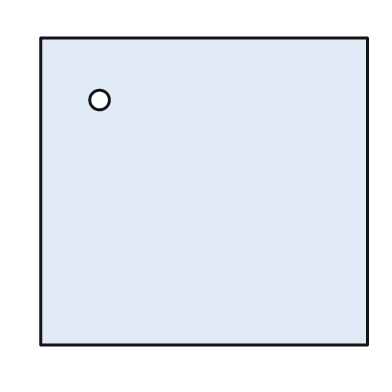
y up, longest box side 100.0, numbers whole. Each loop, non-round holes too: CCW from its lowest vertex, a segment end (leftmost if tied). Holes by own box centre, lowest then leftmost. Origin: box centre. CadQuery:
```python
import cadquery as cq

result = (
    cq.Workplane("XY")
    .moveTo(-50.0, -47.0)
    .lineTo(50.0, -47.0)
    .lineTo(50.0, 47.0)
    .lineTo(-50.0, 47.0)
    .close()
    .moveTo(-32.0, 28.0)
    .circle(3.0)
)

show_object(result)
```